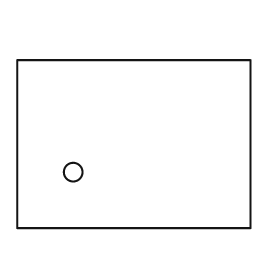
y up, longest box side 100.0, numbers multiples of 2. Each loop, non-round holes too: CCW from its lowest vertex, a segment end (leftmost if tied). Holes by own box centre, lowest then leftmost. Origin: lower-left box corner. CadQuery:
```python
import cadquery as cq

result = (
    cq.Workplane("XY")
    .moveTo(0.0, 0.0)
    .lineTo(100.0, 0.0)
    .lineTo(100.0, 72.0)
    .lineTo(0.0, 72.0)
    .close()
    .moveTo(24.0, 24.0)
    .circle(4.0)
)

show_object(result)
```